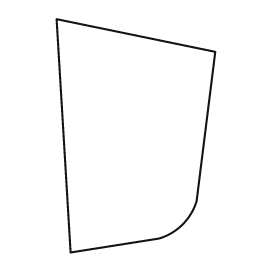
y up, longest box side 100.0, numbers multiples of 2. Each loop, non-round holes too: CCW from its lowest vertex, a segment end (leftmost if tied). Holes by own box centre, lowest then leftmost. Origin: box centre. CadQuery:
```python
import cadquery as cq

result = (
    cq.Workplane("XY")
    .moveTo(-28.0, -50.0)
    .lineTo(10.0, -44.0)
    .threePointArc((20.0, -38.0), (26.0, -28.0))
    .lineTo(34.0, 36.0)
    .lineTo(-34.0, 50.0)
    .close()
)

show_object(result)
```